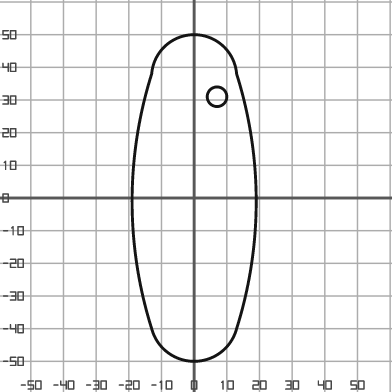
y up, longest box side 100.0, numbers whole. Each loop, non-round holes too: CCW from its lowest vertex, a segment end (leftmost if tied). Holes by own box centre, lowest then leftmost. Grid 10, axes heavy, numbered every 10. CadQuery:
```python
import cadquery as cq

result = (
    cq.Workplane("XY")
    .moveTo(-13.0, -40.0)
    .threePointArc((0.0, -50.0), (13.0, -40.0))
    .threePointArc((19.0, -1.0), (13.0, 38.0))
    .threePointArc((0.0, 50.0), (-13.0, 38.0))
    .threePointArc((-19.0, -1.0), (-13.0, -40.0))
    .close()
    .moveTo(7.0, 31.0)
    .circle(3.0)
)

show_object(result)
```